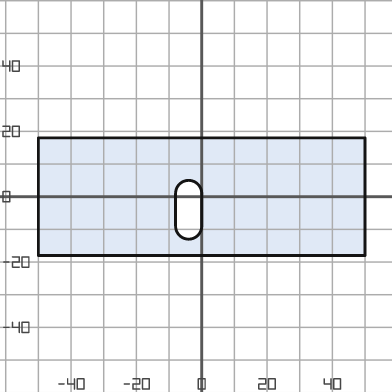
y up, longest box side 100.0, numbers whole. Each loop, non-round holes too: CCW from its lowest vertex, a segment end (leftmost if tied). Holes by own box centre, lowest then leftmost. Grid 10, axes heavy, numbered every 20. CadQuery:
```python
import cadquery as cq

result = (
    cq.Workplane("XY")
    .moveTo(-50.0, -18.0)
    .lineTo(50.0, -18.0)
    .lineTo(50.0, 18.0)
    .lineTo(-50.0, 18.0)
    .close()
    .moveTo(-8.0, -9.0)
    .threePointArc((-4.0, -13.0), (0.0, -9.0))
    .lineTo(0.0, 1.0)
    .threePointArc((-4.0, 5.0), (-8.0, 1.0))
    .close()
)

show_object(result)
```